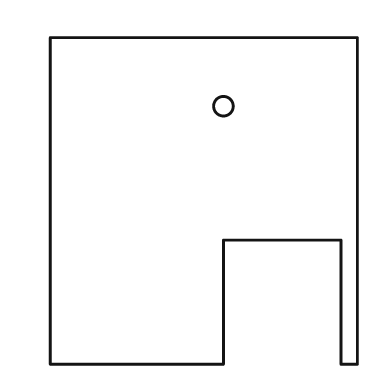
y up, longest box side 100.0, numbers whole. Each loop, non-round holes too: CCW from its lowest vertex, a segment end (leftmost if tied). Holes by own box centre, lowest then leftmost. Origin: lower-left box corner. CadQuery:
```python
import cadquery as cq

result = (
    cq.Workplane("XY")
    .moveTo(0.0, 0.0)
    .lineTo(53.0, 0.0)
    .lineTo(53.0, 38.0)
    .lineTo(89.0, 38.0)
    .lineTo(89.0, 0.0)
    .lineTo(94.0, 0.0)
    .lineTo(94.0, 100.0)
    .lineTo(0.0, 100.0)
    .close()
    .moveTo(53.0, 79.0)
    .circle(3.0)
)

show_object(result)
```